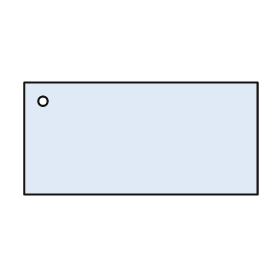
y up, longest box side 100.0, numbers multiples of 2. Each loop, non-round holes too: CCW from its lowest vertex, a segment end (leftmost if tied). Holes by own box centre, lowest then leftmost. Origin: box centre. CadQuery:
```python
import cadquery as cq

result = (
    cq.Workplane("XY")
    .moveTo(-50.0, -24.0)
    .lineTo(50.0, -24.0)
    .lineTo(50.0, 24.0)
    .lineTo(-50.0, 24.0)
    .close()
    .moveTo(-42.0, 16.0)
    .circle(2.0)
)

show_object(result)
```